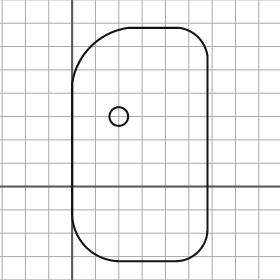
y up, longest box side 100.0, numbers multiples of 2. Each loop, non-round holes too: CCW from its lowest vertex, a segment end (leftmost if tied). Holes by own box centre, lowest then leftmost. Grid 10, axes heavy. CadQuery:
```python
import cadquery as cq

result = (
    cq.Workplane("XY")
    .moveTo(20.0, -32.0)
    .lineTo(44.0, -32.0)
    .threePointArc((54.0, -28.0), (58.0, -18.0))
    .lineTo(58.0, 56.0)
    .threePointArc((54.0, 64.0), (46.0, 68.0))
    .lineTo(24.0, 68.0)
    .threePointArc((8.0, 60.0), (0.0, 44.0))
    .lineTo(0.0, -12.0)
    .threePointArc((6.0, -26.0), (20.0, -32.0))
    .close()
    .moveTo(20.0, 30.0)
    .circle(4.0)
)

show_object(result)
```